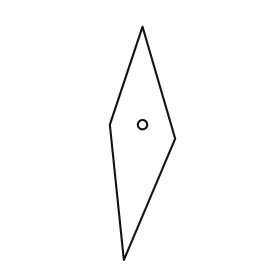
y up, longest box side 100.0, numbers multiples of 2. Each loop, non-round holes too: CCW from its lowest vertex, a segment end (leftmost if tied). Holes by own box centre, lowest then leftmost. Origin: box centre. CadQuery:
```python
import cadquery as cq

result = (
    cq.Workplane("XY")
    .moveTo(-8.0, -50.0)
    .lineTo(14.0, 2.0)
    .lineTo(0.0, 50.0)
    .lineTo(-14.0, 8.0)
    .close()
    .moveTo(0.0, 8.0)
    .circle(2.0)
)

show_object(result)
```